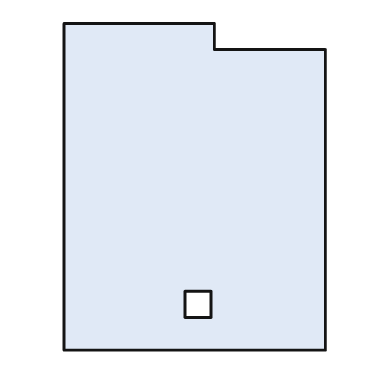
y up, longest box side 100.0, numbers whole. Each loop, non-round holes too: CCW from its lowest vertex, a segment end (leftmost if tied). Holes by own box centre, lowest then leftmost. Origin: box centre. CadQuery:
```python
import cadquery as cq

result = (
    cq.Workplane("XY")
    .moveTo(-40.0, -50.0)
    .lineTo(40.0, -50.0)
    .lineTo(40.0, 42.0)
    .lineTo(6.0, 42.0)
    .lineTo(6.0, 50.0)
    .lineTo(-40.0, 50.0)
    .close()
    .moveTo(-3.0, -40.0)
    .lineTo(5.0, -40.0)
    .lineTo(5.0, -32.0)
    .lineTo(-3.0, -32.0)
    .close()
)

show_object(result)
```